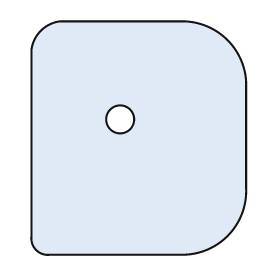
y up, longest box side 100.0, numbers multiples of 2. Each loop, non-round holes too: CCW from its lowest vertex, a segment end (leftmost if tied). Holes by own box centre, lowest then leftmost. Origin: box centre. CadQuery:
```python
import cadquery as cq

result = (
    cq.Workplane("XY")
    .moveTo(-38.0, -50.0)
    .lineTo(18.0, -50.0)
    .threePointArc((38.0, -42.0), (46.0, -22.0))
    .lineTo(46.0, 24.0)
    .threePointArc((38.0, 42.0), (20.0, 50.0))
    .lineTo(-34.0, 50.0)
    .threePointArc((-42.0, 46.0), (-46.0, 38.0))
    .lineTo(-46.0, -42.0)
    .threePointArc((-44.0, -48.0), (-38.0, -50.0))
    .close()
    .moveTo(-8.0, 8.0)
    .circle(6.0)
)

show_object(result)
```